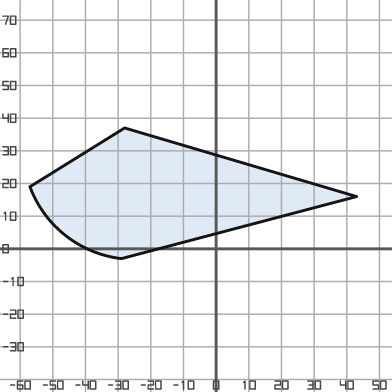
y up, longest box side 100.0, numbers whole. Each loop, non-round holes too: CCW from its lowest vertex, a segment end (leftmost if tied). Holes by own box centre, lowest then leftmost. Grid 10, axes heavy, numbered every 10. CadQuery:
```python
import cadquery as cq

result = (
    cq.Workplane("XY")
    .moveTo(-29.0, -3.0)
    .lineTo(43.0, 16.0)
    .lineTo(-28.0, 37.0)
    .lineTo(-57.0, 19.0)
    .threePointArc((-46.0, 4.0), (-29.0, -3.0))
    .close()
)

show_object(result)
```